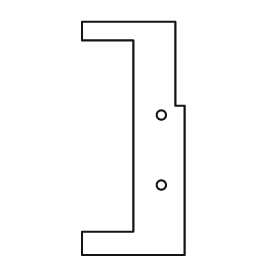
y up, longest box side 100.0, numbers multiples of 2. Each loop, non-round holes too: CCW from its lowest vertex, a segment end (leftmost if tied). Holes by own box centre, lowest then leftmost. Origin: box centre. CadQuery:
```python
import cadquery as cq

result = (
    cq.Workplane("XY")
    .moveTo(-22.0, -50.0)
    .lineTo(22.0, -50.0)
    .lineTo(22.0, 14.0)
    .lineTo(18.0, 14.0)
    .lineTo(18.0, 50.0)
    .lineTo(-22.0, 50.0)
    .lineTo(-22.0, 42.0)
    .lineTo(0.0, 42.0)
    .lineTo(0.0, -40.0)
    .lineTo(-22.0, -40.0)
    .close()
    .moveTo(12.0, -20.0)
    .circle(2.0)
    .moveTo(12.0, 10.0)
    .circle(2.0)
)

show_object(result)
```